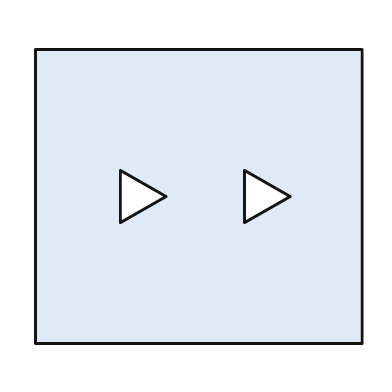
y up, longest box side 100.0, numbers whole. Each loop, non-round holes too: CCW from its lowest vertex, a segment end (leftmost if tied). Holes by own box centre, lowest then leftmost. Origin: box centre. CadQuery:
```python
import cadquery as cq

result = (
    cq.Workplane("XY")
    .moveTo(-50.0, -45.0)
    .lineTo(50.0, -45.0)
    .lineTo(50.0, 45.0)
    .lineTo(-50.0, 45.0)
    .close()
    .moveTo(-24.0, -8.0)
    .lineTo(-10.0, 0.0)
    .lineTo(-24.0, 8.0)
    .close()
    .moveTo(14.0, -8.0)
    .lineTo(28.0, 0.0)
    .lineTo(14.0, 8.0)
    .close()
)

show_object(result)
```